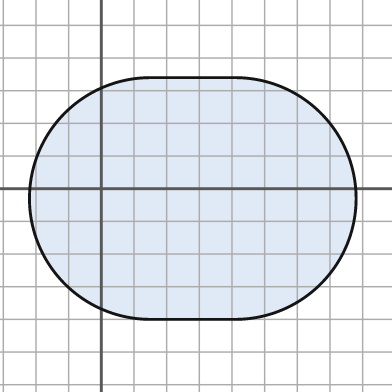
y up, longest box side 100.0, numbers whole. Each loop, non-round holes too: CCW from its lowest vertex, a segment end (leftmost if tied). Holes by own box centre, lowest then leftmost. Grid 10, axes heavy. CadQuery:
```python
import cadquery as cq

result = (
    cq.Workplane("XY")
    .moveTo(15.0, -40.0)
    .lineTo(41.0, -40.0)
    .threePointArc((78.0, -3.0), (41.0, 34.0))
    .lineTo(15.0, 34.0)
    .threePointArc((-22.0, -3.0), (15.0, -40.0))
    .close()
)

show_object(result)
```